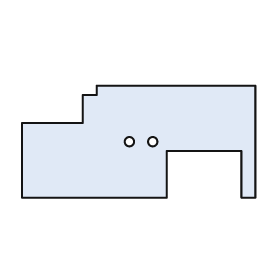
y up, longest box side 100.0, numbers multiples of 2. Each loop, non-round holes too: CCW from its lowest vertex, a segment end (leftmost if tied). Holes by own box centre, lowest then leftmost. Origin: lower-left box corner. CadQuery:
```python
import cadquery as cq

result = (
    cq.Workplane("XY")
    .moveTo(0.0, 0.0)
    .lineTo(62.0, 0.0)
    .lineTo(62.0, 20.0)
    .lineTo(94.0, 20.0)
    .lineTo(94.0, 0.0)
    .lineTo(100.0, 0.0)
    .lineTo(100.0, 48.0)
    .lineTo(32.0, 48.0)
    .lineTo(32.0, 44.0)
    .lineTo(26.0, 44.0)
    .lineTo(26.0, 32.0)
    .lineTo(0.0, 32.0)
    .close()
    .moveTo(46.0, 24.0)
    .circle(2.0)
    .moveTo(56.0, 24.0)
    .circle(2.0)
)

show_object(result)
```